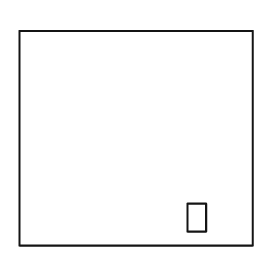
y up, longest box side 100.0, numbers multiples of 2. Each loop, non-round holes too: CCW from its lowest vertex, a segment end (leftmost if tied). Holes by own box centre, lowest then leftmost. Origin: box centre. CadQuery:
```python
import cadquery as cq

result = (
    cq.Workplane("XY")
    .moveTo(-50.0, -46.0)
    .lineTo(50.0, -46.0)
    .lineTo(50.0, 46.0)
    .lineTo(-50.0, 46.0)
    .close()
    .moveTo(22.0, -40.0)
    .lineTo(30.0, -40.0)
    .lineTo(30.0, -28.0)
    .lineTo(22.0, -28.0)
    .close()
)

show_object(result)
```